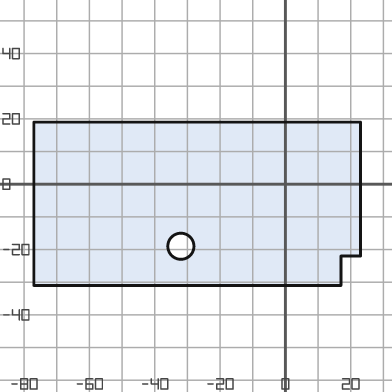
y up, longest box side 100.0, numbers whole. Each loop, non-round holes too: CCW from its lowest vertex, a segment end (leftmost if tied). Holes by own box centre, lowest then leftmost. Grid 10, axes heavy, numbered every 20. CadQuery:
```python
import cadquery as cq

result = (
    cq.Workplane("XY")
    .moveTo(-77.0, -31.0)
    .lineTo(17.0, -31.0)
    .lineTo(17.0, -22.0)
    .lineTo(23.0, -22.0)
    .lineTo(23.0, 19.0)
    .lineTo(-77.0, 19.0)
    .close()
    .moveTo(-32.0, -19.0)
    .circle(4.0)
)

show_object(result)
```